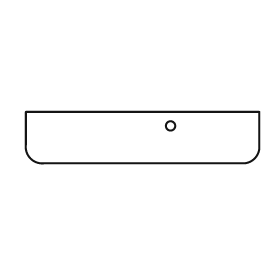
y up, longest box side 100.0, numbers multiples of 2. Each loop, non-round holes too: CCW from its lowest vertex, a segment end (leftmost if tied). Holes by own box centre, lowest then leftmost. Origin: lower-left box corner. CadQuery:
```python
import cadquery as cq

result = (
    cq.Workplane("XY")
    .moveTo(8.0, 0.0)
    .lineTo(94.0, 0.0)
    .threePointArc((98.0, 2.0), (100.0, 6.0))
    .lineTo(100.0, 22.0)
    .lineTo(0.0, 22.0)
    .lineTo(0.0, 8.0)
    .threePointArc((2.0, 2.0), (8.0, 0.0))
    .close()
    .moveTo(62.0, 16.0)
    .circle(2.0)
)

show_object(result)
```